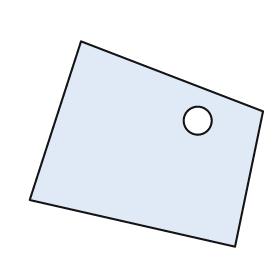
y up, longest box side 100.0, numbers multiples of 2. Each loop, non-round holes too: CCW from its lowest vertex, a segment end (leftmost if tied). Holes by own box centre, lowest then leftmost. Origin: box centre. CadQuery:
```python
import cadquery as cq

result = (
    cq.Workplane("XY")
    .moveTo(38.0, -44.0)
    .lineTo(50.0, 14.0)
    .lineTo(-28.0, 44.0)
    .lineTo(-50.0, -24.0)
    .close()
    .moveTo(22.0, 10.0)
    .circle(6.0)
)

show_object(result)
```